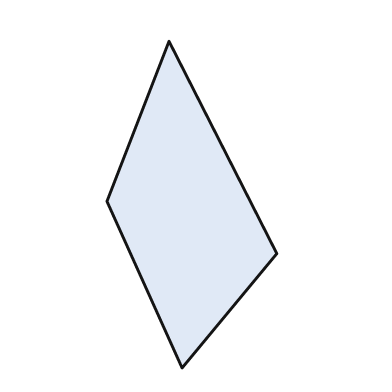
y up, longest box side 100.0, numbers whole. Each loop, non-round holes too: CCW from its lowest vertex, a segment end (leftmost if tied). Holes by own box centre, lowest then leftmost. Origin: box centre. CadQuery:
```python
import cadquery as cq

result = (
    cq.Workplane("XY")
    .moveTo(-3.0, -50.0)
    .lineTo(26.0, -15.0)
    .lineTo(-7.0, 50.0)
    .lineTo(-26.0, 1.0)
    .close()
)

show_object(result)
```